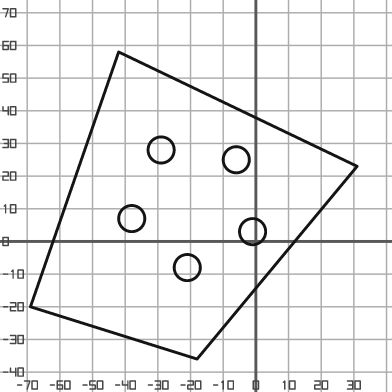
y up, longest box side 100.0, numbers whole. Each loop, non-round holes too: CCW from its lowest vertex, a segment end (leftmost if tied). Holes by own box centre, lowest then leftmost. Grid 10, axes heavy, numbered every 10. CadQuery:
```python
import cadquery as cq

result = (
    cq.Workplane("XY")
    .moveTo(-18.0, -36.0)
    .lineTo(31.0, 23.0)
    .lineTo(-42.0, 58.0)
    .lineTo(-69.0, -20.0)
    .close()
    .moveTo(-21.0, -8.0)
    .circle(4.0)
    .moveTo(-1.0, 3.0)
    .circle(4.0)
    .moveTo(-38.0, 7.0)
    .circle(4.0)
    .moveTo(-6.0, 25.0)
    .circle(4.0)
    .moveTo(-29.0, 28.0)
    .circle(4.0)
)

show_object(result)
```